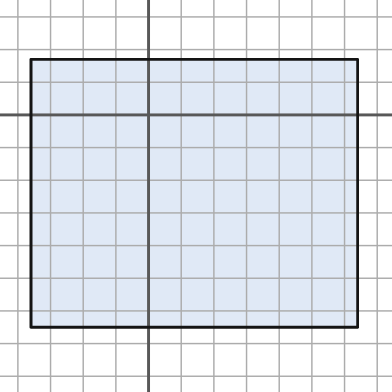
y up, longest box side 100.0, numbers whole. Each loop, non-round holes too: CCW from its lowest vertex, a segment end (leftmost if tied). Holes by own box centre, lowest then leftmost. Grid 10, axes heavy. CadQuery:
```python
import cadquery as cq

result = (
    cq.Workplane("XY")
    .moveTo(-36.0, -65.0)
    .lineTo(64.0, -65.0)
    .lineTo(64.0, 17.0)
    .lineTo(-36.0, 17.0)
    .close()
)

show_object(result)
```